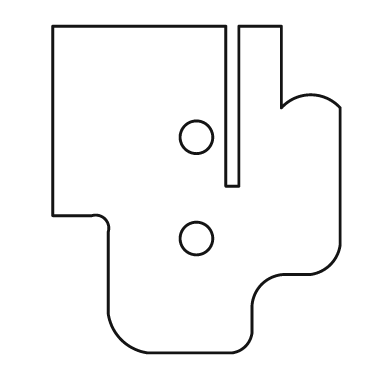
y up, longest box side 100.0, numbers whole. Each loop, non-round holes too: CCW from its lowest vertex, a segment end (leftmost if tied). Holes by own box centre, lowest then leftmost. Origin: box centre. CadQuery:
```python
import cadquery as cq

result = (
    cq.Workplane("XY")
    .moveTo(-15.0, -50.0)
    .lineTo(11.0, -50.0)
    .threePointArc((15.0, -48.0), (17.0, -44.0))
    .lineTo(17.0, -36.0)
    .threePointArc((20.0, -29.0), (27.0, -26.0))
    .lineTo(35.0, -26.0)
    .threePointArc((41.0, -23.0), (44.0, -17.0))
    .lineTo(44.0, 25.0)
    .threePointArc((35.0, 29.0), (26.0, 25.0))
    .lineTo(26.0, 50.0)
    .lineTo(13.0, 50.0)
    .lineTo(13.0, 1.0)
    .lineTo(9.0, 1.0)
    .lineTo(9.0, 50.0)
    .lineTo(-44.0, 50.0)
    .lineTo(-44.0, -8.0)
    .lineTo(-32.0, -8.0)
    .threePointArc((-28.0, -9.0), (-27.0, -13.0))
    .lineTo(-27.0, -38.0)
    .threePointArc((-23.0, -46.0), (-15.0, -50.0))
    .close()
    .moveTo(0.0, -15.0)
    .circle(5.0)
    .moveTo(0.0, 16.0)
    .circle(5.0)
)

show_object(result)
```